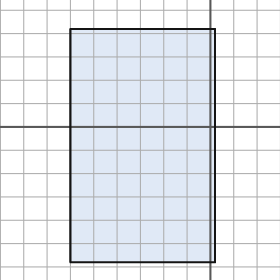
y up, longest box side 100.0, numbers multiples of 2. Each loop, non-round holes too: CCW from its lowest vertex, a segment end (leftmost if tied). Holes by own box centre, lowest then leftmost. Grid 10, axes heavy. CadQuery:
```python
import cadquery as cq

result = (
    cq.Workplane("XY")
    .moveTo(-60.0, -58.0)
    .lineTo(2.0, -58.0)
    .lineTo(2.0, 42.0)
    .lineTo(-60.0, 42.0)
    .close()
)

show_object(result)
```